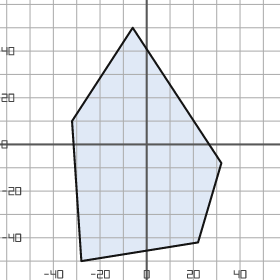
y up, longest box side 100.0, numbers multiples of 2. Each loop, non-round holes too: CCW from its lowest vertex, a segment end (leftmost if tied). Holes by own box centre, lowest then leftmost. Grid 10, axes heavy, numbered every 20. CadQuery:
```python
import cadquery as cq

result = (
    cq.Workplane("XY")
    .moveTo(-28.0, -50.0)
    .lineTo(22.0, -42.0)
    .lineTo(32.0, -8.0)
    .lineTo(-6.0, 50.0)
    .lineTo(-32.0, 10.0)
    .close()
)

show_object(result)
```